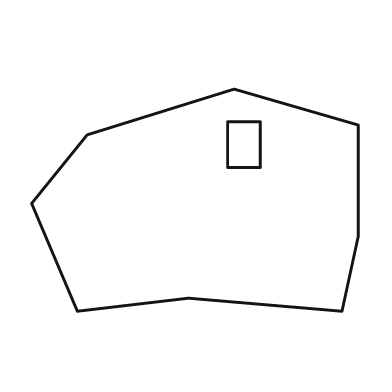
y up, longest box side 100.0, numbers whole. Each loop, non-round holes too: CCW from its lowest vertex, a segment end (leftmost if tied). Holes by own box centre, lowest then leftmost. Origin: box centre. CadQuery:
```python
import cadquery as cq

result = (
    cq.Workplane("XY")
    .moveTo(-36.0, -34.0)
    .lineTo(-2.0, -30.0)
    .lineTo(45.0, -34.0)
    .lineTo(50.0, -11.0)
    .lineTo(50.0, 23.0)
    .lineTo(12.0, 34.0)
    .lineTo(-33.0, 20.0)
    .lineTo(-50.0, -1.0)
    .close()
    .moveTo(10.0, 10.0)
    .lineTo(20.0, 10.0)
    .lineTo(20.0, 24.0)
    .lineTo(10.0, 24.0)
    .close()
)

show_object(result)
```